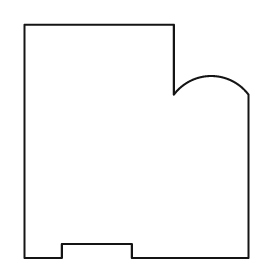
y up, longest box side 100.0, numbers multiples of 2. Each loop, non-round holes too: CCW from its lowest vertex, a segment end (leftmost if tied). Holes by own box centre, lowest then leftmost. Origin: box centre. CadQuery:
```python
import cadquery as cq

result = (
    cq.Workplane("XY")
    .moveTo(-48.0, -50.0)
    .lineTo(-32.0, -50.0)
    .lineTo(-32.0, -44.0)
    .lineTo(-2.0, -44.0)
    .lineTo(-2.0, -50.0)
    .lineTo(48.0, -50.0)
    .lineTo(48.0, 20.0)
    .threePointArc((32.0, 28.0), (16.0, 20.0))
    .lineTo(16.0, 50.0)
    .lineTo(-48.0, 50.0)
    .close()
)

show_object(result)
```